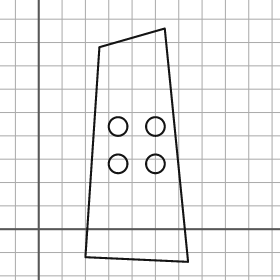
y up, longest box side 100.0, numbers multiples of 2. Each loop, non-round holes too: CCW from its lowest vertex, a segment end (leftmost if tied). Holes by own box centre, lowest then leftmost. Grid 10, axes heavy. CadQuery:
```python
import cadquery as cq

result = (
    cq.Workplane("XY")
    .moveTo(64.0, -14.0)
    .lineTo(54.0, 86.0)
    .lineTo(26.0, 78.0)
    .lineTo(20.0, -12.0)
    .close()
    .moveTo(34.0, 28.0)
    .circle(4.0)
    .moveTo(50.0, 28.0)
    .circle(4.0)
    .moveTo(34.0, 44.0)
    .circle(4.0)
    .moveTo(50.0, 44.0)
    .circle(4.0)
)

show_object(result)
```